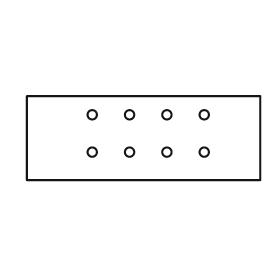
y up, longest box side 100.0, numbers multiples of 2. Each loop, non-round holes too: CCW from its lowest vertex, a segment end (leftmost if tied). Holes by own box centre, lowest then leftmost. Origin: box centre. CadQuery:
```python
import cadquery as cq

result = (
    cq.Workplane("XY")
    .moveTo(-50.0, -18.0)
    .lineTo(50.0, -18.0)
    .lineTo(50.0, 18.0)
    .lineTo(-50.0, 18.0)
    .close()
    .moveTo(-22.0, -6.0)
    .circle(2.0)
    .moveTo(-6.0, -6.0)
    .circle(2.0)
    .moveTo(10.0, -6.0)
    .circle(2.0)
    .moveTo(26.0, -6.0)
    .circle(2.0)
    .moveTo(-22.0, 10.0)
    .circle(2.0)
    .moveTo(-6.0, 10.0)
    .circle(2.0)
    .moveTo(10.0, 10.0)
    .circle(2.0)
    .moveTo(26.0, 10.0)
    .circle(2.0)
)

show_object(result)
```